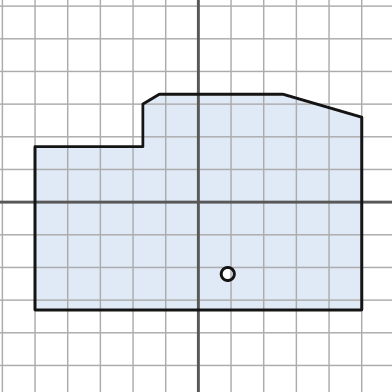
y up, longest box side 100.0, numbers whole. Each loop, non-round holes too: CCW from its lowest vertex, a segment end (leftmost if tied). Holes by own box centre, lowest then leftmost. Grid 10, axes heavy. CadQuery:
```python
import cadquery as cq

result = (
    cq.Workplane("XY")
    .moveTo(-50.0, -33.0)
    .lineTo(50.0, -33.0)
    .lineTo(50.0, 26.0)
    .lineTo(26.0, 33.0)
    .lineTo(-12.0, 33.0)
    .lineTo(-17.0, 30.0)
    .lineTo(-17.0, 17.0)
    .lineTo(-50.0, 17.0)
    .close()
    .moveTo(9.0, -22.0)
    .circle(2.0)
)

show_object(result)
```